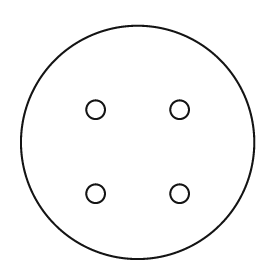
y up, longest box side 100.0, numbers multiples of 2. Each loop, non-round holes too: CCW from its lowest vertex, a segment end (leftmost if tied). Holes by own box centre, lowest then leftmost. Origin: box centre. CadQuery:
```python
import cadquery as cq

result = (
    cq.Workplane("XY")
    .moveTo(0.0, 0.0)
    .circle(50.0)
    .moveTo(-18.0, -22.0)
    .circle(4.0)
    .moveTo(18.0, -22.0)
    .circle(4.0)
    .moveTo(-18.0, 14.0)
    .circle(4.0)
    .moveTo(18.0, 14.0)
    .circle(4.0)
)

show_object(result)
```